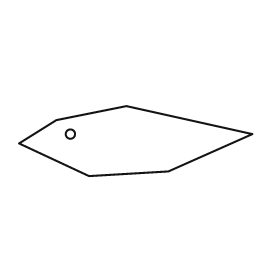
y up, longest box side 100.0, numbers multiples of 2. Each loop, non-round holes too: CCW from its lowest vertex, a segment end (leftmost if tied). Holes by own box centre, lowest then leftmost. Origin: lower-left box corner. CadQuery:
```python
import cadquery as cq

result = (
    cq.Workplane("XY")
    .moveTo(30.0, 0.0)
    .lineTo(64.0, 2.0)
    .lineTo(100.0, 18.0)
    .lineTo(46.0, 30.0)
    .lineTo(16.0, 24.0)
    .lineTo(0.0, 14.0)
    .close()
    .moveTo(22.0, 18.0)
    .circle(2.0)
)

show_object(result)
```